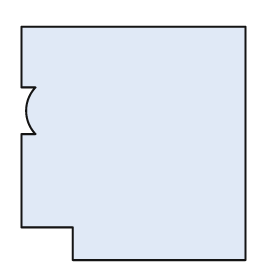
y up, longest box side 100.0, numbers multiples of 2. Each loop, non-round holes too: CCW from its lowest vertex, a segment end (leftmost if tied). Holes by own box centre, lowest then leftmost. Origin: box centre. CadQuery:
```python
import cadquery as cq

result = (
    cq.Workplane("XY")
    .moveTo(-26.0, -50.0)
    .lineTo(48.0, -50.0)
    .lineTo(48.0, 50.0)
    .lineTo(-48.0, 50.0)
    .lineTo(-48.0, 24.0)
    .lineTo(-42.0, 24.0)
    .threePointArc((-46.0, 14.0), (-42.0, 4.0))
    .lineTo(-48.0, 4.0)
    .lineTo(-48.0, -36.0)
    .lineTo(-26.0, -36.0)
    .close()
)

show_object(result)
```